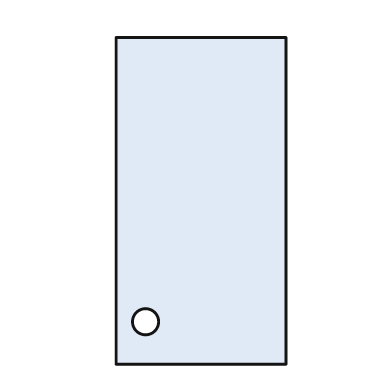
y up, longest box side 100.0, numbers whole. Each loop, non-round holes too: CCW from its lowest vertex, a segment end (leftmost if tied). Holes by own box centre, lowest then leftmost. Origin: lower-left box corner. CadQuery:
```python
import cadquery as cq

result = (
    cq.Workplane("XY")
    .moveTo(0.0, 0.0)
    .lineTo(52.0, 0.0)
    .lineTo(52.0, 100.0)
    .lineTo(0.0, 100.0)
    .close()
    .moveTo(9.0, 13.0)
    .circle(4.0)
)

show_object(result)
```